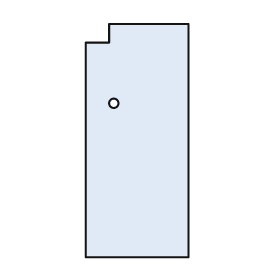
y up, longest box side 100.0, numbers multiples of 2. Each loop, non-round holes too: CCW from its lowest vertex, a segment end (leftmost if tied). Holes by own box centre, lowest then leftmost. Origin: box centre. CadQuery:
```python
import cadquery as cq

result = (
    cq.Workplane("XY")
    .moveTo(-22.0, -50.0)
    .lineTo(22.0, -50.0)
    .lineTo(22.0, 50.0)
    .lineTo(-12.0, 50.0)
    .lineTo(-12.0, 42.0)
    .lineTo(-22.0, 42.0)
    .close()
    .moveTo(-10.0, 16.0)
    .circle(2.0)
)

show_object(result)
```